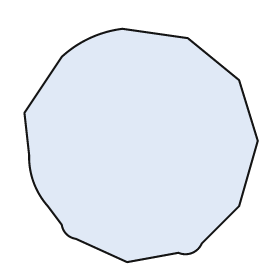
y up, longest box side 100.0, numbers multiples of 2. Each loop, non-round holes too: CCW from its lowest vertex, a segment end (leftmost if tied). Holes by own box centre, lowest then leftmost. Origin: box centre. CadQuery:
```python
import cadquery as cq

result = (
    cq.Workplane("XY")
    .moveTo(-6.0, -50.0)
    .lineTo(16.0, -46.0)
    .threePointArc((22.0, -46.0), (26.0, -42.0))
    .lineTo(42.0, -26.0)
    .lineTo(50.0, 2.0)
    .lineTo(42.0, 28.0)
    .lineTo(20.0, 46.0)
    .lineTo(-8.0, 50.0)
    .threePointArc((-22.0, 46.0), (-34.0, 38.0))
    .lineTo(-50.0, 14.0)
    .lineTo(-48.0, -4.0)
    .threePointArc((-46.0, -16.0), (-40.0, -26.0))
    .lineTo(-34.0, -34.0)
    .threePointArc((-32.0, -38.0), (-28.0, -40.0))
    .close()
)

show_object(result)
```